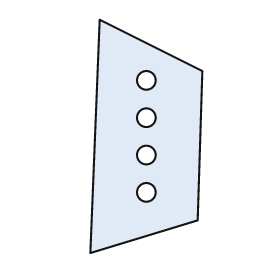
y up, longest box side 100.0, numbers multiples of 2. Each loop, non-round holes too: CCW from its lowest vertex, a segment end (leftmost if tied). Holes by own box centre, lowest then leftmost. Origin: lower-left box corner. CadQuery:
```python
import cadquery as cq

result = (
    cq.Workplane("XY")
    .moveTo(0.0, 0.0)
    .lineTo(46.0, 14.0)
    .lineTo(48.0, 78.0)
    .lineTo(4.0, 100.0)
    .close()
    .moveTo(24.0, 26.0)
    .circle(4.0)
    .moveTo(24.0, 42.0)
    .circle(4.0)
    .moveTo(24.0, 58.0)
    .circle(4.0)
    .moveTo(24.0, 74.0)
    .circle(4.0)
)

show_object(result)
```